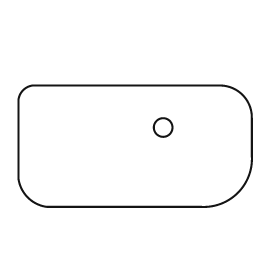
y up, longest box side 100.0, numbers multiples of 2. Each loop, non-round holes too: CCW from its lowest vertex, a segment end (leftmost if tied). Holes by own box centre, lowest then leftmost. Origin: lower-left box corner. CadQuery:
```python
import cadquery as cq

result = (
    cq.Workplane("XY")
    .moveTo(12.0, 0.0)
    .lineTo(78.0, 0.0)
    .threePointArc((94.0, 6.0), (100.0, 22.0))
    .lineTo(100.0, 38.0)
    .threePointArc((96.0, 48.0), (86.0, 52.0))
    .lineTo(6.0, 52.0)
    .threePointArc((2.0, 50.0), (0.0, 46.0))
    .lineTo(0.0, 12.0)
    .threePointArc((4.0, 4.0), (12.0, 0.0))
    .close()
    .moveTo(62.0, 34.0)
    .circle(4.0)
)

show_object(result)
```